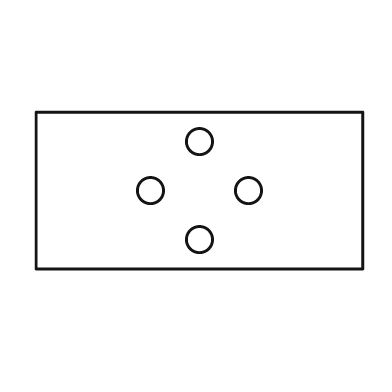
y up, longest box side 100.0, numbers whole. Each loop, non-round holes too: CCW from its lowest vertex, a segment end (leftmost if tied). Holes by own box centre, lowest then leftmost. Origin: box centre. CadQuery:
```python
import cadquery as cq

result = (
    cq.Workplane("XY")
    .moveTo(-50.0, -24.0)
    .lineTo(50.0, -24.0)
    .lineTo(50.0, 24.0)
    .lineTo(-50.0, 24.0)
    .close()
    .moveTo(0.0, -15.0)
    .circle(4.0)
    .moveTo(-15.0, 0.0)
    .circle(4.0)
    .moveTo(15.0, 0.0)
    .circle(4.0)
    .moveTo(0.0, 15.0)
    .circle(4.0)
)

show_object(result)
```